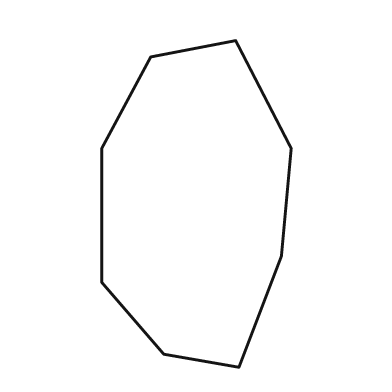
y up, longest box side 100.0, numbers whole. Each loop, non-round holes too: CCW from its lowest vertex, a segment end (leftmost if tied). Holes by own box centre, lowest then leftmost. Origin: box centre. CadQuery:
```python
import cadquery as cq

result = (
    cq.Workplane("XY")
    .moveTo(13.0, -50.0)
    .lineTo(26.0, -16.0)
    .lineTo(29.0, 17.0)
    .lineTo(12.0, 50.0)
    .lineTo(-14.0, 45.0)
    .lineTo(-29.0, 17.0)
    .lineTo(-29.0, -24.0)
    .lineTo(-10.0, -46.0)
    .close()
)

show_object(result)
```